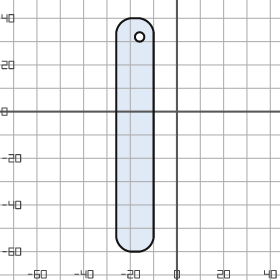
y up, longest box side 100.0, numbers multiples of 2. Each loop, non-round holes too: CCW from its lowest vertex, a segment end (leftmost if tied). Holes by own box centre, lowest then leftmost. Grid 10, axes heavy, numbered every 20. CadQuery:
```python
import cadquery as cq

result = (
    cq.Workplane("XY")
    .moveTo(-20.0, -60.0)
    .lineTo(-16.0, -60.0)
    .threePointArc((-12.0, -58.0), (-10.0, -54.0))
    .lineTo(-10.0, 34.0)
    .threePointArc((-12.0, 38.0), (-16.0, 40.0))
    .lineTo(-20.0, 40.0)
    .threePointArc((-24.0, 38.0), (-26.0, 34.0))
    .lineTo(-26.0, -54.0)
    .threePointArc((-24.0, -58.0), (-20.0, -60.0))
    .close()
    .moveTo(-16.0, 32.0)
    .circle(2.0)
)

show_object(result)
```